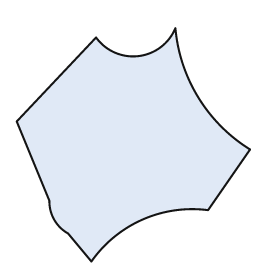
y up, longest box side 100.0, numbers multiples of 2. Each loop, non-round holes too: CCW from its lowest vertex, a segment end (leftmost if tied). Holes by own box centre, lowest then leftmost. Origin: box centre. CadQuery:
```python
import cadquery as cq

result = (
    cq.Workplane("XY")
    .moveTo(-18.0, -50.0)
    .threePointArc((4.0, -32.0), (32.0, -28.0))
    .lineTo(50.0, -2.0)
    .threePointArc((28.0, 20.0), (18.0, 50.0))
    .threePointArc((2.0, 38.0), (-16.0, 46.0))
    .lineTo(-50.0, 10.0)
    .lineTo(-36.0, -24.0)
    .threePointArc((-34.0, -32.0), (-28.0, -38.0))
    .close()
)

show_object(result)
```